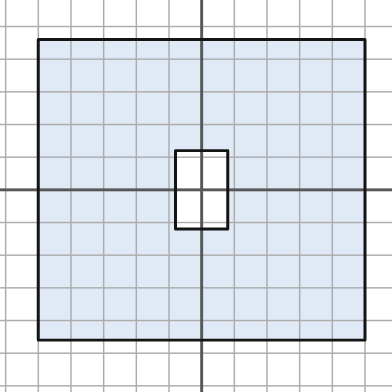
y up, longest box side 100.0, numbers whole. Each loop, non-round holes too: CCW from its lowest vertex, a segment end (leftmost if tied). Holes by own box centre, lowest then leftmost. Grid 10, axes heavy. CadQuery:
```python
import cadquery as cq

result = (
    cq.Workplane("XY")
    .moveTo(-50.0, -46.0)
    .lineTo(50.0, -46.0)
    .lineTo(50.0, 46.0)
    .lineTo(-50.0, 46.0)
    .close()
    .moveTo(-8.0, -12.0)
    .lineTo(8.0, -12.0)
    .lineTo(8.0, 12.0)
    .lineTo(-8.0, 12.0)
    .close()
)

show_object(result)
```